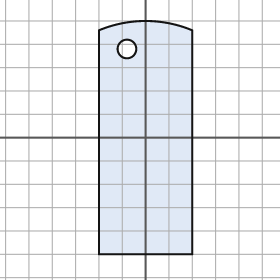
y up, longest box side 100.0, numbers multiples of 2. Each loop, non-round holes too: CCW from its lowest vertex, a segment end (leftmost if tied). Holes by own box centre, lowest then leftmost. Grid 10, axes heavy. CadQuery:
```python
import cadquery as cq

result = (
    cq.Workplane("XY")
    .moveTo(-20.0, -50.0)
    .lineTo(20.0, -50.0)
    .lineTo(20.0, 46.0)
    .threePointArc((0.0, 50.0), (-20.0, 46.0))
    .close()
    .moveTo(-8.0, 38.0)
    .circle(4.0)
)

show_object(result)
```